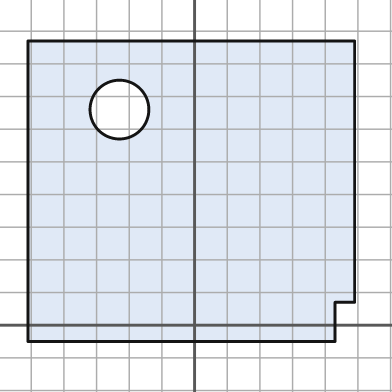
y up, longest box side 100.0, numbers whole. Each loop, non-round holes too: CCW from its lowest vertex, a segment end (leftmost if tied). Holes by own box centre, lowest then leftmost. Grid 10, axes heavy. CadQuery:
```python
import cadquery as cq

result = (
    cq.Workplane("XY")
    .moveTo(-51.0, -5.0)
    .lineTo(43.0, -5.0)
    .lineTo(43.0, 7.0)
    .lineTo(49.0, 7.0)
    .lineTo(49.0, 87.0)
    .lineTo(-51.0, 87.0)
    .close()
    .moveTo(-23.0, 66.0)
    .circle(9.0)
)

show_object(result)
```